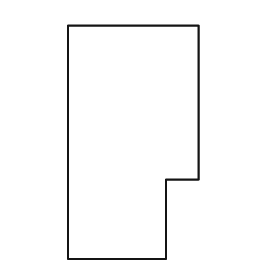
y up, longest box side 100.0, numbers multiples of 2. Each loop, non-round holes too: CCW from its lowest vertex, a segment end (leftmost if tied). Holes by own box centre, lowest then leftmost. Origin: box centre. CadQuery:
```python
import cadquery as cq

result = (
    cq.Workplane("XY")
    .moveTo(-28.0, -50.0)
    .lineTo(14.0, -50.0)
    .lineTo(14.0, -16.0)
    .lineTo(28.0, -16.0)
    .lineTo(28.0, 50.0)
    .lineTo(-28.0, 50.0)
    .close()
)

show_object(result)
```